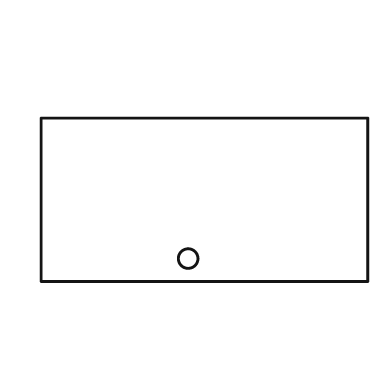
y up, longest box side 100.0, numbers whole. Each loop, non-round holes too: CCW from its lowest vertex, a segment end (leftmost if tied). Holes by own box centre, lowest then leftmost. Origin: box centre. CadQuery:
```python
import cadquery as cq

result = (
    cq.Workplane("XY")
    .moveTo(-50.0, -25.0)
    .lineTo(50.0, -25.0)
    .lineTo(50.0, 25.0)
    .lineTo(-50.0, 25.0)
    .close()
    .moveTo(-5.0, -18.0)
    .circle(3.0)
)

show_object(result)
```